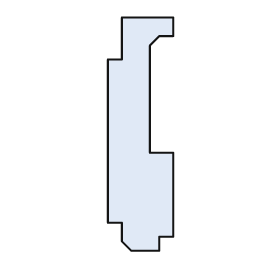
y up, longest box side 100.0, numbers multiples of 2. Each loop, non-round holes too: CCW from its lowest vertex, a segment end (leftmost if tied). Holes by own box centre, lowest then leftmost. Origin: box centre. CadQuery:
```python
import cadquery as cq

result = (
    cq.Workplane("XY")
    .moveTo(-4.0, -50.0)
    .lineTo(8.0, -50.0)
    .lineTo(8.0, -44.0)
    .lineTo(14.0, -44.0)
    .lineTo(14.0, -8.0)
    .lineTo(4.0, -8.0)
    .lineTo(4.0, 38.0)
    .lineTo(8.0, 42.0)
    .lineTo(14.0, 42.0)
    .lineTo(14.0, 50.0)
    .lineTo(-8.0, 50.0)
    .lineTo(-8.0, 32.0)
    .lineTo(-14.0, 32.0)
    .lineTo(-14.0, -38.0)
    .lineTo(-8.0, -38.0)
    .lineTo(-8.0, -46.0)
    .close()
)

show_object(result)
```